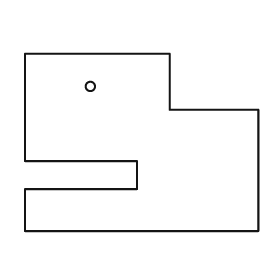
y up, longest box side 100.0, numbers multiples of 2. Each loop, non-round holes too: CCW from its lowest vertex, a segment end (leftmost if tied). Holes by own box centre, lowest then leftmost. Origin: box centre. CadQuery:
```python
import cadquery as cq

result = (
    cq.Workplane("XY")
    .moveTo(-50.0, -38.0)
    .lineTo(50.0, -38.0)
    .lineTo(50.0, 14.0)
    .lineTo(12.0, 14.0)
    .lineTo(12.0, 38.0)
    .lineTo(-50.0, 38.0)
    .lineTo(-50.0, -8.0)
    .lineTo(-2.0, -8.0)
    .lineTo(-2.0, -20.0)
    .lineTo(-50.0, -20.0)
    .close()
    .moveTo(-22.0, 24.0)
    .circle(2.0)
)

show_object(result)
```